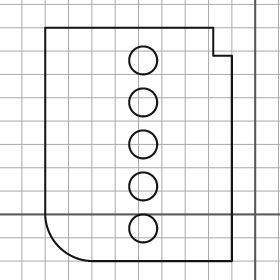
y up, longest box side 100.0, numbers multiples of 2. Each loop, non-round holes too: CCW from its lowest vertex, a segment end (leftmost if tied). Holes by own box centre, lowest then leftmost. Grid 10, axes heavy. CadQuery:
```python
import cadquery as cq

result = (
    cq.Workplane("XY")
    .moveTo(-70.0, -20.0)
    .lineTo(-10.0, -20.0)
    .lineTo(-10.0, 68.0)
    .lineTo(-18.0, 68.0)
    .lineTo(-18.0, 80.0)
    .lineTo(-90.0, 80.0)
    .lineTo(-90.0, 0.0)
    .threePointArc((-84.0, -14.0), (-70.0, -20.0))
    .close()
    .moveTo(-48.0, -6.0)
    .circle(6.0)
    .moveTo(-48.0, 12.0)
    .circle(6.0)
    .moveTo(-48.0, 30.0)
    .circle(6.0)
    .moveTo(-48.0, 48.0)
    .circle(6.0)
    .moveTo(-48.0, 66.0)
    .circle(6.0)
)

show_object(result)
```